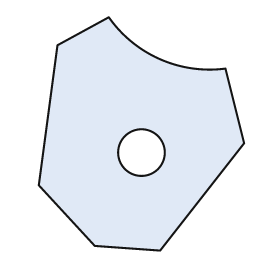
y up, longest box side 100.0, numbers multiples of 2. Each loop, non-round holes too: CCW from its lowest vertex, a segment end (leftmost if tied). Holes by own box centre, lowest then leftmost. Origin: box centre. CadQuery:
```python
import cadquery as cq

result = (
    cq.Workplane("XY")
    .moveTo(8.0, -50.0)
    .lineTo(44.0, -4.0)
    .lineTo(36.0, 28.0)
    .threePointArc((8.0, 32.0), (-14.0, 50.0))
    .lineTo(-36.0, 38.0)
    .lineTo(-44.0, -22.0)
    .lineTo(-20.0, -48.0)
    .close()
    .moveTo(0.0, -8.0)
    .circle(10.0)
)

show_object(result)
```